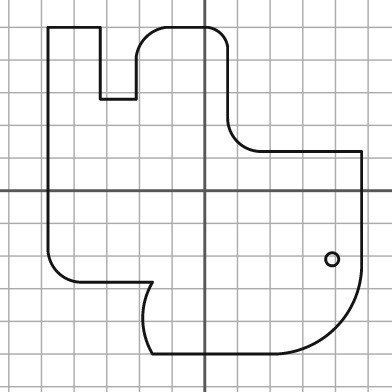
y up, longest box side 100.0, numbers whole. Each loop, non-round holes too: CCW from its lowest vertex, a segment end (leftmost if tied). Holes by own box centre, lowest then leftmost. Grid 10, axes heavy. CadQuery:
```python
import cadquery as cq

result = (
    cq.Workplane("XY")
    .moveTo(-16.0, -50.0)
    .lineTo(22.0, -50.0)
    .threePointArc((40.0, -42.0), (48.0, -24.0))
    .lineTo(48.0, 12.0)
    .lineTo(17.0, 12.0)
    .threePointArc((10.0, 15.0), (7.0, 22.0))
    .lineTo(7.0, 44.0)
    .threePointArc((5.0, 48.0), (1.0, 50.0))
    .lineTo(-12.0, 50.0)
    .threePointArc((-18.0, 47.0), (-21.0, 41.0))
    .lineTo(-21.0, 28.0)
    .lineTo(-32.0, 28.0)
    .lineTo(-32.0, 50.0)
    .lineTo(-48.0, 50.0)
    .lineTo(-48.0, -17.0)
    .threePointArc((-45.0, -25.0), (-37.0, -28.0))
    .lineTo(-16.0, -28.0)
    .threePointArc((-19.0, -39.0), (-16.0, -50.0))
    .close()
    .moveTo(39.0, -21.0)
    .circle(2.0)
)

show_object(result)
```